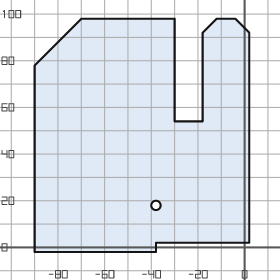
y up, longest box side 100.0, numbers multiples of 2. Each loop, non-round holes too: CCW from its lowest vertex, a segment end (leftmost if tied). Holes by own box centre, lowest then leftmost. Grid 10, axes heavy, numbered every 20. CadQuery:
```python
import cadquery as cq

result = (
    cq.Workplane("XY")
    .moveTo(-90.0, -2.0)
    .lineTo(-38.0, -2.0)
    .lineTo(-38.0, 2.0)
    .lineTo(2.0, 2.0)
    .lineTo(2.0, 92.0)
    .lineTo(-4.0, 98.0)
    .lineTo(-12.0, 98.0)
    .lineTo(-18.0, 92.0)
    .lineTo(-18.0, 54.0)
    .lineTo(-30.0, 54.0)
    .lineTo(-30.0, 98.0)
    .lineTo(-70.0, 98.0)
    .lineTo(-90.0, 78.0)
    .close()
    .moveTo(-38.0, 18.0)
    .circle(2.0)
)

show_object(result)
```